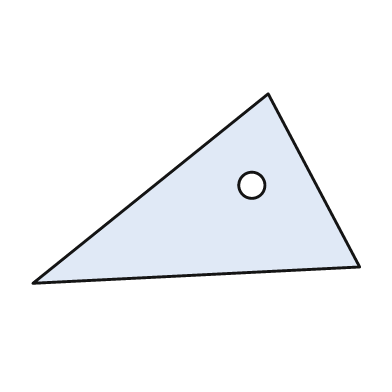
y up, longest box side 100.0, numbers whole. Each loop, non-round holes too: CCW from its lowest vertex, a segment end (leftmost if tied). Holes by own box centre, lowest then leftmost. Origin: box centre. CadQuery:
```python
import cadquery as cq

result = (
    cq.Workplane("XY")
    .moveTo(-50.0, -29.0)
    .lineTo(50.0, -24.0)
    .lineTo(22.0, 29.0)
    .close()
    .moveTo(17.0, 1.0)
    .circle(4.0)
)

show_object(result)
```